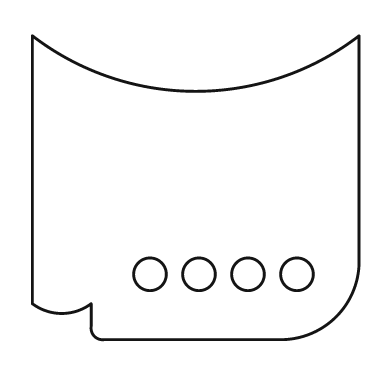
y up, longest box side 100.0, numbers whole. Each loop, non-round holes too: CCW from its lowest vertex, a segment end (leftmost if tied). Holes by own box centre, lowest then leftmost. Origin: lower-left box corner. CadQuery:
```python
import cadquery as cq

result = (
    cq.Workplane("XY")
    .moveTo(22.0, 0.0)
    .lineTo(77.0, 0.0)
    .threePointArc((93.0, 7.0), (100.0, 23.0))
    .lineTo(100.0, 93.0)
    .threePointArc((50.0, 76.0), (0.0, 93.0))
    .lineTo(0.0, 11.0)
    .threePointArc((9.0, 8.0), (18.0, 11.0))
    .lineTo(18.0, 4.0)
    .threePointArc((19.0, 1.0), (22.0, 0.0))
    .close()
    .moveTo(36.0, 20.0)
    .circle(5.0)
    .moveTo(51.0, 20.0)
    .circle(5.0)
    .moveTo(66.0, 20.0)
    .circle(5.0)
    .moveTo(81.0, 20.0)
    .circle(5.0)
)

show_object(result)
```